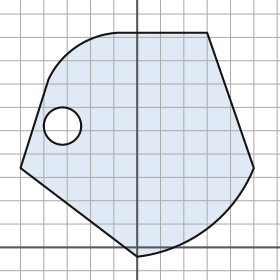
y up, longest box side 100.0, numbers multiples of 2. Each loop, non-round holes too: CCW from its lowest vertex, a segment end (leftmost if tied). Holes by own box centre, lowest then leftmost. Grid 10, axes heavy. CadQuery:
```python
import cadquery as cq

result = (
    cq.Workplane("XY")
    .moveTo(0.0, -4.0)
    .threePointArc((30.0, 8.0), (50.0, 34.0))
    .lineTo(30.0, 92.0)
    .lineTo(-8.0, 92.0)
    .threePointArc((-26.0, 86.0), (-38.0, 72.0))
    .lineTo(-50.0, 34.0)
    .close()
    .moveTo(-32.0, 52.0)
    .circle(8.0)
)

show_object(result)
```